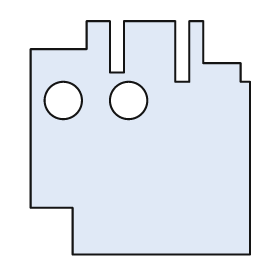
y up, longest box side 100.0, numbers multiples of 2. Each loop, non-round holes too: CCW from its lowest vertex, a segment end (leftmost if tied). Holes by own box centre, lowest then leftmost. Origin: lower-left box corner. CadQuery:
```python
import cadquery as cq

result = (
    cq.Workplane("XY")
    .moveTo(18.0, 0.0)
    .lineTo(94.0, 0.0)
    .lineTo(94.0, 74.0)
    .lineTo(90.0, 74.0)
    .lineTo(90.0, 82.0)
    .lineTo(74.0, 82.0)
    .lineTo(74.0, 100.0)
    .lineTo(68.0, 100.0)
    .lineTo(68.0, 74.0)
    .lineTo(62.0, 74.0)
    .lineTo(62.0, 100.0)
    .lineTo(40.0, 100.0)
    .lineTo(40.0, 78.0)
    .lineTo(34.0, 78.0)
    .lineTo(34.0, 100.0)
    .lineTo(24.0, 100.0)
    .lineTo(24.0, 88.0)
    .lineTo(0.0, 88.0)
    .lineTo(0.0, 20.0)
    .lineTo(18.0, 20.0)
    .close()
    .moveTo(14.0, 66.0)
    .circle(8.0)
    .moveTo(42.0, 66.0)
    .circle(8.0)
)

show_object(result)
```